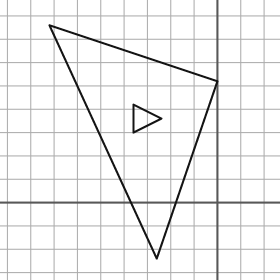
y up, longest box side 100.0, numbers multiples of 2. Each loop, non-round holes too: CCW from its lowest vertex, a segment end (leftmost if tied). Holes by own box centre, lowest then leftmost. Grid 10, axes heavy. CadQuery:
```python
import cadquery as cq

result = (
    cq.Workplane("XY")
    .moveTo(-26.0, -24.0)
    .lineTo(0.0, 52.0)
    .lineTo(-72.0, 76.0)
    .close()
    .moveTo(-36.0, 30.0)
    .lineTo(-24.0, 36.0)
    .lineTo(-36.0, 42.0)
    .close()
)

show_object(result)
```